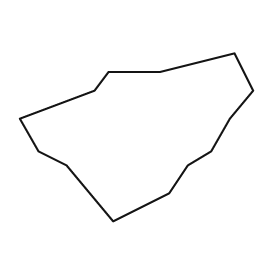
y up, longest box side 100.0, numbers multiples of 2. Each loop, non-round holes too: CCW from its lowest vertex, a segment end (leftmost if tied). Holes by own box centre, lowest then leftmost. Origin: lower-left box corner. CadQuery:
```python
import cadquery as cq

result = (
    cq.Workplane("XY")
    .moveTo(40.0, 0.0)
    .lineTo(64.0, 12.0)
    .lineTo(72.0, 24.0)
    .lineTo(82.0, 30.0)
    .lineTo(90.0, 44.0)
    .lineTo(100.0, 56.0)
    .lineTo(92.0, 72.0)
    .lineTo(60.0, 64.0)
    .lineTo(38.0, 64.0)
    .lineTo(32.0, 56.0)
    .lineTo(0.0, 44.0)
    .lineTo(8.0, 30.0)
    .lineTo(20.0, 24.0)
    .close()
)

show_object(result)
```